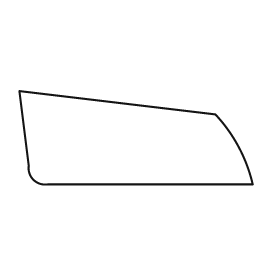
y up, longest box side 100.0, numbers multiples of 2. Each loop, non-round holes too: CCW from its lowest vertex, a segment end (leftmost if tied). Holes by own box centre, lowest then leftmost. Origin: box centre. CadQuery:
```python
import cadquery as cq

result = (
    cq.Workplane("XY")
    .moveTo(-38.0, -20.0)
    .lineTo(50.0, -20.0)
    .threePointArc((44.0, -4.0), (34.0, 10.0))
    .lineTo(-50.0, 20.0)
    .lineTo(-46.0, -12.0)
    .threePointArc((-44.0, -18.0), (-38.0, -20.0))
    .close()
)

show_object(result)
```